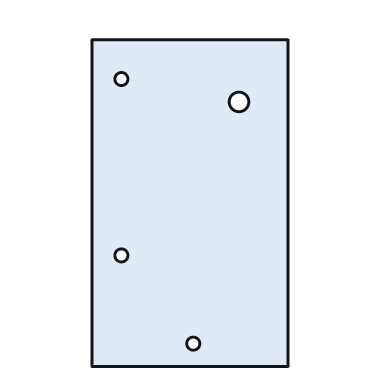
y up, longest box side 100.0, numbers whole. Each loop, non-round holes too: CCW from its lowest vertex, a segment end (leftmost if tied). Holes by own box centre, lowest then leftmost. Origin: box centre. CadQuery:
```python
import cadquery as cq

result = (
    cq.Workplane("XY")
    .moveTo(-30.0, -50.0)
    .lineTo(30.0, -50.0)
    .lineTo(30.0, 50.0)
    .lineTo(-30.0, 50.0)
    .close()
    .moveTo(1.0, -43.0)
    .circle(2.0)
    .moveTo(-21.0, -16.0)
    .circle(2.0)
    .moveTo(15.0, 31.0)
    .circle(3.0)
    .moveTo(-21.0, 38.0)
    .circle(2.0)
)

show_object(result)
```